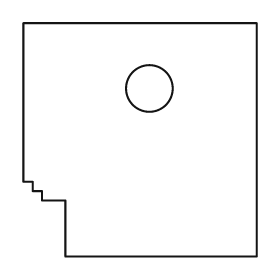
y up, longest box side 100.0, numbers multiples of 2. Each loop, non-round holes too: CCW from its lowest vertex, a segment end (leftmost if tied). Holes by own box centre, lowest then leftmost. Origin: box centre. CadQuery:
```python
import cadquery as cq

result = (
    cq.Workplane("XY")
    .moveTo(-32.0, -50.0)
    .lineTo(50.0, -50.0)
    .lineTo(50.0, 50.0)
    .lineTo(-50.0, 50.0)
    .lineTo(-50.0, -18.0)
    .lineTo(-46.0, -18.0)
    .lineTo(-46.0, -22.0)
    .lineTo(-42.0, -22.0)
    .lineTo(-42.0, -26.0)
    .lineTo(-32.0, -26.0)
    .close()
    .moveTo(4.0, 22.0)
    .circle(10.0)
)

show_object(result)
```